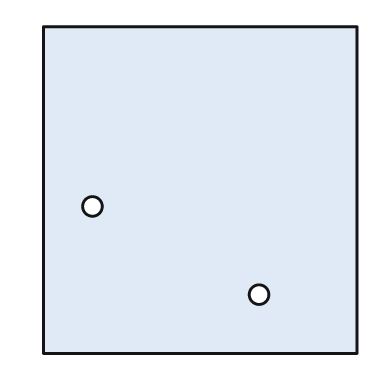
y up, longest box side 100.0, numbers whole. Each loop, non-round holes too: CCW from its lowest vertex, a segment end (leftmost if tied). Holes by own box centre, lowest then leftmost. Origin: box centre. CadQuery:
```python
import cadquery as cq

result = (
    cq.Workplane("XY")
    .moveTo(-48.0, -50.0)
    .lineTo(48.0, -50.0)
    .lineTo(48.0, 50.0)
    .lineTo(-48.0, 50.0)
    .close()
    .moveTo(18.0, -32.0)
    .circle(3.0)
    .moveTo(-33.0, -5.0)
    .circle(3.0)
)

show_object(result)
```